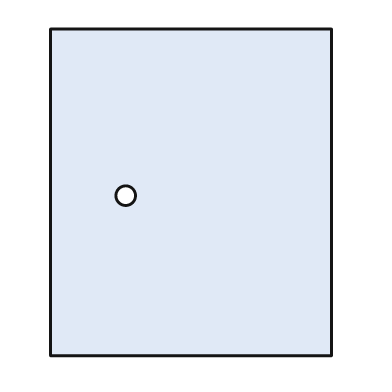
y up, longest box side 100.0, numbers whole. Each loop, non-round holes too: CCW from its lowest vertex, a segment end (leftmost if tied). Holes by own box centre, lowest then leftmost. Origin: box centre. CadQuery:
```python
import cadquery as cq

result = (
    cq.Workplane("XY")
    .moveTo(-43.0, -50.0)
    .lineTo(43.0, -50.0)
    .lineTo(43.0, 50.0)
    .lineTo(-43.0, 50.0)
    .close()
    .moveTo(-20.0, -1.0)
    .circle(3.0)
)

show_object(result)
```